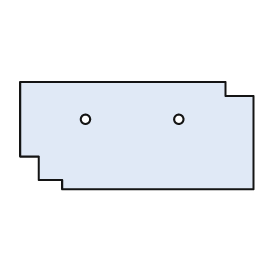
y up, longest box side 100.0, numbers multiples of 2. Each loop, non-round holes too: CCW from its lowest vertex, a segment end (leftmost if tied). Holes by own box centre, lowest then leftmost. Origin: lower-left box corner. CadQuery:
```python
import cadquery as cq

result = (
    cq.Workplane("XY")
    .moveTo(18.0, 0.0)
    .lineTo(100.0, 0.0)
    .lineTo(100.0, 40.0)
    .lineTo(88.0, 40.0)
    .lineTo(88.0, 46.0)
    .lineTo(0.0, 46.0)
    .lineTo(0.0, 14.0)
    .lineTo(8.0, 14.0)
    .lineTo(8.0, 4.0)
    .lineTo(18.0, 4.0)
    .close()
    .moveTo(28.0, 30.0)
    .circle(2.0)
    .moveTo(68.0, 30.0)
    .circle(2.0)
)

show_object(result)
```